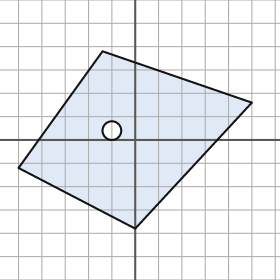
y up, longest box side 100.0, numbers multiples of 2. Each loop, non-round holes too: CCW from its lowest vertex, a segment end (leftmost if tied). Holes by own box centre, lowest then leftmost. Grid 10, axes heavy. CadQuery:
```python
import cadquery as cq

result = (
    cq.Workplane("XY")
    .moveTo(0.0, -38.0)
    .lineTo(50.0, 16.0)
    .lineTo(-14.0, 38.0)
    .lineTo(-50.0, -12.0)
    .close()
    .moveTo(-10.0, 4.0)
    .circle(4.0)
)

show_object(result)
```